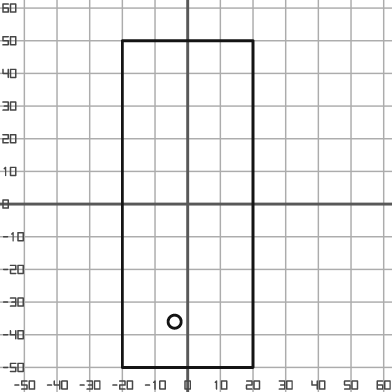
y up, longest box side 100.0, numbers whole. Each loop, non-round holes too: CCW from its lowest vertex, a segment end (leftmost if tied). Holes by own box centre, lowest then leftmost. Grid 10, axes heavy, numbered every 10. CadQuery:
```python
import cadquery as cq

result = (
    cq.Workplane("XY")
    .moveTo(-20.0, -50.0)
    .lineTo(20.0, -50.0)
    .lineTo(20.0, 50.0)
    .lineTo(-20.0, 50.0)
    .close()
    .moveTo(-4.0, -36.0)
    .circle(2.0)
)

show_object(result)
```